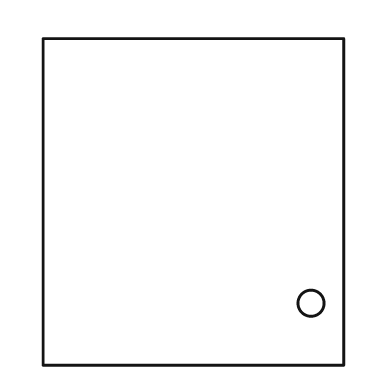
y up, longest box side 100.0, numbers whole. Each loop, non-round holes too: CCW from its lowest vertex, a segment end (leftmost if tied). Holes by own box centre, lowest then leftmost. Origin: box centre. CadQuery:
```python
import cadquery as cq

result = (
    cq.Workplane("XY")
    .moveTo(-46.0, -50.0)
    .lineTo(46.0, -50.0)
    .lineTo(46.0, 50.0)
    .lineTo(-46.0, 50.0)
    .close()
    .moveTo(36.0, -31.0)
    .circle(4.0)
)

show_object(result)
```